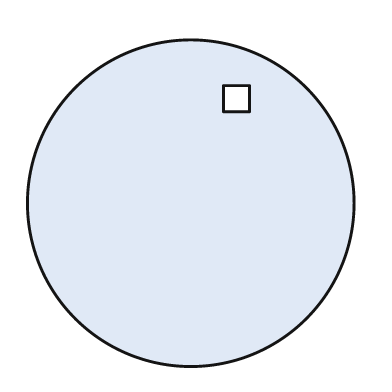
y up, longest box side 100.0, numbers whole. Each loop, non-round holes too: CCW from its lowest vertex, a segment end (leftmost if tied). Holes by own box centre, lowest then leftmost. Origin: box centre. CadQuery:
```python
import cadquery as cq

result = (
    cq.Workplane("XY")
    .moveTo(0.0, 0.0)
    .circle(50.0)
    .moveTo(10.0, 28.0)
    .lineTo(18.0, 28.0)
    .lineTo(18.0, 36.0)
    .lineTo(10.0, 36.0)
    .close()
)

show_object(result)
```